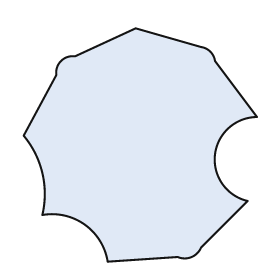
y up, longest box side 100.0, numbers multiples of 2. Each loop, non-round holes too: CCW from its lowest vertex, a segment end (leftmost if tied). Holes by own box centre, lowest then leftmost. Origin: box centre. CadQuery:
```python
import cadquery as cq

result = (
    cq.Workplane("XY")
    .moveTo(-14.0, -50.0)
    .lineTo(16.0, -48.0)
    .threePointArc((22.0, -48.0), (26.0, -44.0))
    .lineTo(46.0, -24.0)
    .threePointArc((32.0, -4.0), (50.0, 12.0))
    .lineTo(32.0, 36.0)
    .threePointArc((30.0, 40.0), (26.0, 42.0))
    .lineTo(-2.0, 50.0)
    .lineTo(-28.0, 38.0)
    .threePointArc((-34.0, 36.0), (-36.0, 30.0))
    .lineTo(-50.0, 4.0)
    .threePointArc((-42.0, -12.0), (-42.0, -30.0))
    .threePointArc((-24.0, -34.0), (-14.0, -50.0))
    .close()
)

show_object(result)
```